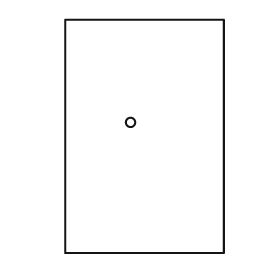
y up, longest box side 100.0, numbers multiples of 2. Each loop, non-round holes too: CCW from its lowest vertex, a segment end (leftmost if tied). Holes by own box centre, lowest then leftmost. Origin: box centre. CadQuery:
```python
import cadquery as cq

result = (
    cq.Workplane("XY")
    .moveTo(-34.0, -50.0)
    .lineTo(34.0, -50.0)
    .lineTo(34.0, 50.0)
    .lineTo(-34.0, 50.0)
    .close()
    .moveTo(-6.0, 6.0)
    .circle(2.0)
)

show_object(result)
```